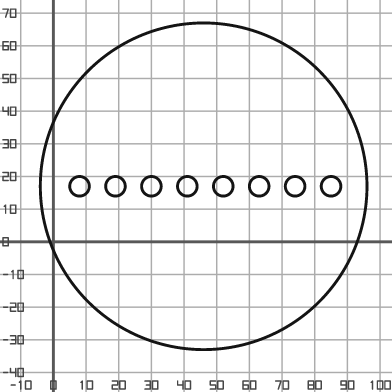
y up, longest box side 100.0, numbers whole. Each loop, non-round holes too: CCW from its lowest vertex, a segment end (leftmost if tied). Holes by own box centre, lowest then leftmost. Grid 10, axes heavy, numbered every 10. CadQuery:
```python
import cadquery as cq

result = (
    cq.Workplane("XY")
    .moveTo(46.0, 17.0)
    .circle(50.0)
    .moveTo(8.0, 17.0)
    .circle(3.0)
    .moveTo(19.0, 17.0)
    .circle(3.0)
    .moveTo(30.0, 17.0)
    .circle(3.0)
    .moveTo(41.0, 17.0)
    .circle(3.0)
    .moveTo(52.0, 17.0)
    .circle(3.0)
    .moveTo(63.0, 17.0)
    .circle(3.0)
    .moveTo(74.0, 17.0)
    .circle(3.0)
    .moveTo(85.0, 17.0)
    .circle(3.0)
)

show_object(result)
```